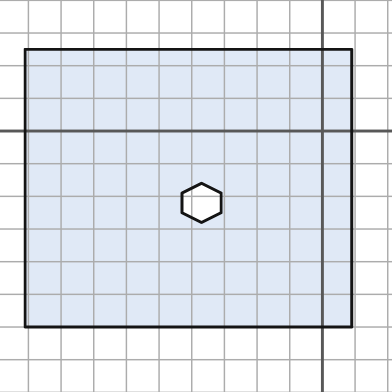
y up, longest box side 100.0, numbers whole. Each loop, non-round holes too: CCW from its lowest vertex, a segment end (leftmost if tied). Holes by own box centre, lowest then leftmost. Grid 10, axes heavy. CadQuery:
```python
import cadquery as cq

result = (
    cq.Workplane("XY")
    .moveTo(-91.0, -60.0)
    .lineTo(9.0, -60.0)
    .lineTo(9.0, 25.0)
    .lineTo(-91.0, 25.0)
    .close()
    .moveTo(-37.0, -28.0)
    .lineTo(-31.0, -25.0)
    .lineTo(-31.0, -19.0)
    .lineTo(-37.0, -16.0)
    .lineTo(-43.0, -19.0)
    .lineTo(-43.0, -25.0)
    .close()
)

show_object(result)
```